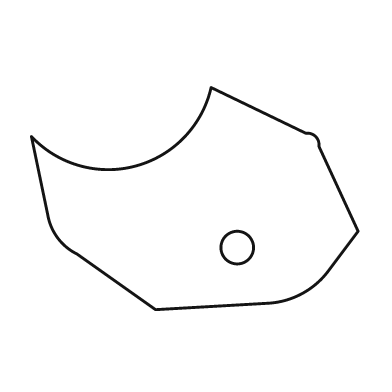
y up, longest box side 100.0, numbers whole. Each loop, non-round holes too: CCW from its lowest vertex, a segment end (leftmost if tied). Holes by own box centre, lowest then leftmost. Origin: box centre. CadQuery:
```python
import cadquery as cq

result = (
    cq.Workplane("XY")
    .moveTo(-12.0, -34.0)
    .lineTo(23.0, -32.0)
    .threePointArc((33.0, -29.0), (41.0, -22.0))
    .lineTo(50.0, -10.0)
    .lineTo(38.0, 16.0)
    .threePointArc((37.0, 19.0), (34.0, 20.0))
    .lineTo(5.0, 34.0)
    .threePointArc((-18.0, 10.0), (-50.0, 19.0))
    .lineTo(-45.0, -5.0)
    .threePointArc((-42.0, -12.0), (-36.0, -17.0))
    .close()
    .moveTo(13.0, -15.0)
    .circle(5.0)
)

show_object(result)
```